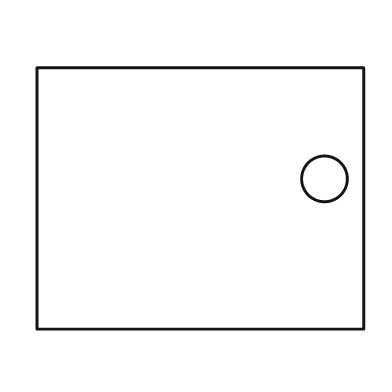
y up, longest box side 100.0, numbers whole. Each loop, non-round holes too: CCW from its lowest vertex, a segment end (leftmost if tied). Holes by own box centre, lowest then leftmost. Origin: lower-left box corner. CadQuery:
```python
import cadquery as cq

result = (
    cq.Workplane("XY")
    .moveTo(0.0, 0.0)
    .lineTo(100.0, 0.0)
    .lineTo(100.0, 80.0)
    .lineTo(0.0, 80.0)
    .close()
    .moveTo(88.0, 46.0)
    .circle(7.0)
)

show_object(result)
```